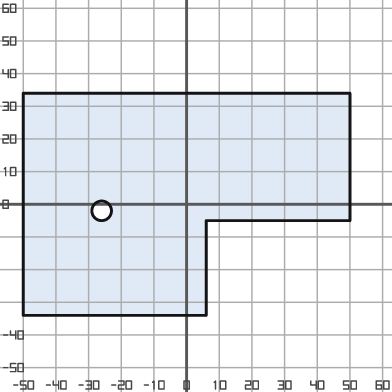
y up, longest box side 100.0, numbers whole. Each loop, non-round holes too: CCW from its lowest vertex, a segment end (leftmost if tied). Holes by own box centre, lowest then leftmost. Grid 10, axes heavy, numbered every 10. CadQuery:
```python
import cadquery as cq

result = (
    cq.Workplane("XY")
    .moveTo(-50.0, -34.0)
    .lineTo(6.0, -34.0)
    .lineTo(6.0, -5.0)
    .lineTo(50.0, -5.0)
    .lineTo(50.0, 34.0)
    .lineTo(-50.0, 34.0)
    .close()
    .moveTo(-26.0, -2.0)
    .circle(3.0)
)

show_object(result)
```